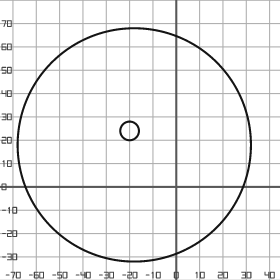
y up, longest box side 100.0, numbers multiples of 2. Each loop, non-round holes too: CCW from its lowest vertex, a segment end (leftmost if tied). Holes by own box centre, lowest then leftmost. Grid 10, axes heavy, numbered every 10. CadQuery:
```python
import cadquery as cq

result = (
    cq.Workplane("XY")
    .moveTo(-18.0, 18.0)
    .circle(50.0)
    .moveTo(-20.0, 24.0)
    .circle(4.0)
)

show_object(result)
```